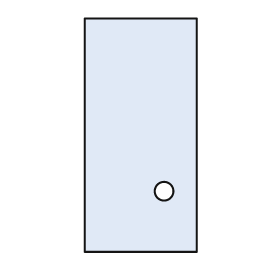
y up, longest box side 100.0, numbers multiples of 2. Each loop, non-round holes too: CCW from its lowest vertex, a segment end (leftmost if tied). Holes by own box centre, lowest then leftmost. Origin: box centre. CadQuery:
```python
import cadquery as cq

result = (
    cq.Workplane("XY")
    .moveTo(-24.0, -50.0)
    .lineTo(24.0, -50.0)
    .lineTo(24.0, 50.0)
    .lineTo(-24.0, 50.0)
    .close()
    .moveTo(10.0, -24.0)
    .circle(4.0)
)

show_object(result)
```